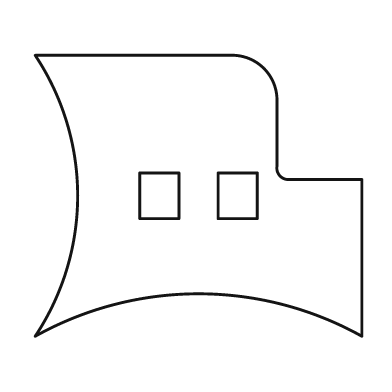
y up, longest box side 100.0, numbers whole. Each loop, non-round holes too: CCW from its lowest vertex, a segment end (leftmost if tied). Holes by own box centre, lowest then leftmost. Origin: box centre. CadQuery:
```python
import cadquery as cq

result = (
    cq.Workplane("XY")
    .moveTo(-50.0, -43.0)
    .threePointArc((0.0, -30.0), (50.0, -43.0))
    .lineTo(50.0, 5.0)
    .lineTo(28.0, 5.0)
    .threePointArc((25.0, 6.0), (24.0, 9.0))
    .lineTo(24.0, 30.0)
    .threePointArc((20.0, 39.0), (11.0, 43.0))
    .lineTo(-50.0, 43.0)
    .threePointArc((-37.0, 0.0), (-50.0, -43.0))
    .close()
    .moveTo(-18.0, -7.0)
    .lineTo(-6.0, -7.0)
    .lineTo(-6.0, 7.0)
    .lineTo(-18.0, 7.0)
    .close()
    .moveTo(6.0, -7.0)
    .lineTo(18.0, -7.0)
    .lineTo(18.0, 7.0)
    .lineTo(6.0, 7.0)
    .close()
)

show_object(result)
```